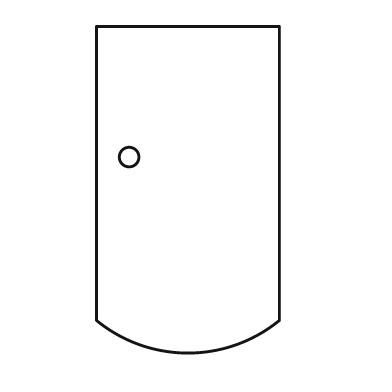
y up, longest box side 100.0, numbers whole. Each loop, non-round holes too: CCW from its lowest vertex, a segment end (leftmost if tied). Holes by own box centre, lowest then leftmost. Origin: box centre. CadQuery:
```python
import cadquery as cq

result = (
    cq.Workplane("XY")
    .moveTo(-28.0, -40.0)
    .threePointArc((0.0, -50.0), (28.0, -40.0))
    .lineTo(28.0, 50.0)
    .lineTo(-28.0, 50.0)
    .close()
    .moveTo(-18.0, 10.0)
    .circle(3.0)
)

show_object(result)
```